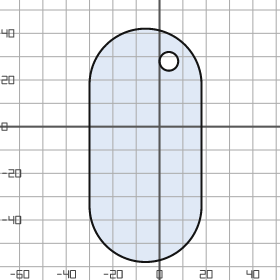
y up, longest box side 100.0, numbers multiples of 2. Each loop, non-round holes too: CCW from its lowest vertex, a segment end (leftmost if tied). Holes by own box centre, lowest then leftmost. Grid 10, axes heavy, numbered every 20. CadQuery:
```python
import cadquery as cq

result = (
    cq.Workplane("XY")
    .moveTo(-30.0, -34.0)
    .threePointArc((-6.0, -58.0), (18.0, -34.0))
    .lineTo(18.0, 18.0)
    .threePointArc((-6.0, 42.0), (-30.0, 18.0))
    .close()
    .moveTo(4.0, 28.0)
    .circle(4.0)
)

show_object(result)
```